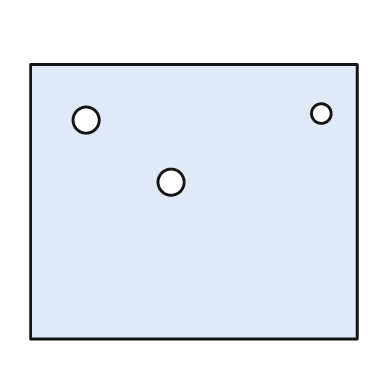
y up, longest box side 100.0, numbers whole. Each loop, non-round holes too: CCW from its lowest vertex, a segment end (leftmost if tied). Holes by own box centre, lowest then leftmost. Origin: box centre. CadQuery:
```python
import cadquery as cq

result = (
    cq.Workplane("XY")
    .moveTo(-50.0, -42.0)
    .lineTo(50.0, -42.0)
    .lineTo(50.0, 42.0)
    .lineTo(-50.0, 42.0)
    .close()
    .moveTo(-7.0, 6.0)
    .circle(4.0)
    .moveTo(-33.0, 25.0)
    .circle(4.0)
    .moveTo(39.0, 27.0)
    .circle(3.0)
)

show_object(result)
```